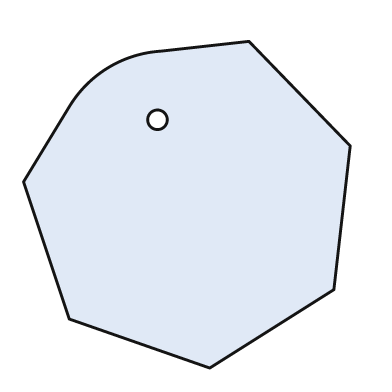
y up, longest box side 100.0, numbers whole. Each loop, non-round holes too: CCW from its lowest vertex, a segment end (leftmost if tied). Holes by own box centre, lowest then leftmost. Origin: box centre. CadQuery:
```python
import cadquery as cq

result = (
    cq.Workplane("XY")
    .moveTo(7.0, -50.0)
    .lineTo(45.0, -26.0)
    .lineTo(50.0, 18.0)
    .lineTo(19.0, 50.0)
    .lineTo(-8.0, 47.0)
    .threePointArc((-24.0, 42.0), (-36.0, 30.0))
    .lineTo(-50.0, 7.0)
    .lineTo(-36.0, -35.0)
    .close()
    .moveTo(-9.0, 26.0)
    .circle(3.0)
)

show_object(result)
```